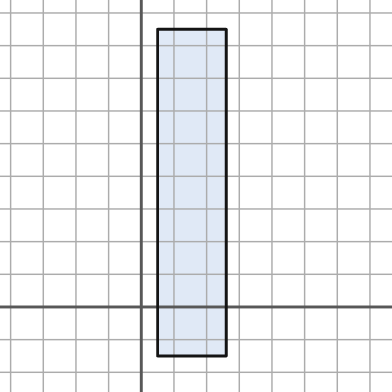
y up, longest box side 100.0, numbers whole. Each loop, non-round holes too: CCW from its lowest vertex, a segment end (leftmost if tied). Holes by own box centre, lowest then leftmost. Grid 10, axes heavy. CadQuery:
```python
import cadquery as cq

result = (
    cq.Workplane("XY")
    .moveTo(5.0, -15.0)
    .lineTo(26.0, -15.0)
    .lineTo(26.0, 85.0)
    .lineTo(5.0, 85.0)
    .close()
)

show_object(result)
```